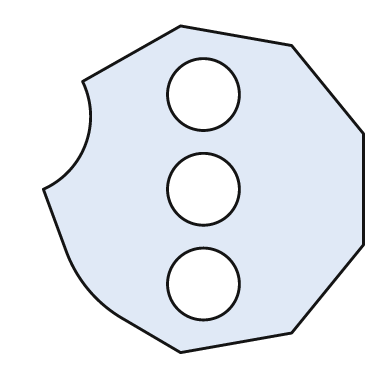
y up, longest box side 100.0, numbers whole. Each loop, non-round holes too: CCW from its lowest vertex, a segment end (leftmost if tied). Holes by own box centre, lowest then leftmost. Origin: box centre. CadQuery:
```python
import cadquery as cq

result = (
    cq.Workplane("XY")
    .moveTo(-7.0, -50.0)
    .lineTo(27.0, -44.0)
    .lineTo(49.0, -17.0)
    .lineTo(49.0, 17.0)
    .lineTo(27.0, 44.0)
    .lineTo(-7.0, 50.0)
    .lineTo(-37.0, 33.0)
    .threePointArc((-36.0, 14.0), (-49.0, 0.0))
    .lineTo(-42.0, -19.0)
    .threePointArc((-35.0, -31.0), (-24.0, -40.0))
    .close()
    .moveTo(0.0, -29.0)
    .circle(11.0)
    .moveTo(0.0, 0.0)
    .circle(11.0)
    .moveTo(0.0, 29.0)
    .circle(11.0)
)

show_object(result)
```